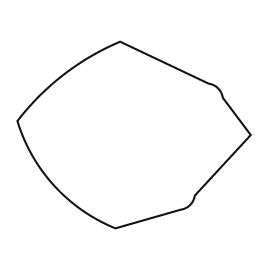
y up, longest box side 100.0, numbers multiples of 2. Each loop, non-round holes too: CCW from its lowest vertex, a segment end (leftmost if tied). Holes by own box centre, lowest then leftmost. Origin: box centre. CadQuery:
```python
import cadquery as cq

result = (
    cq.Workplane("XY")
    .moveTo(-8.0, -40.0)
    .lineTo(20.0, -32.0)
    .threePointArc((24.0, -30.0), (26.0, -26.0))
    .lineTo(50.0, 0.0)
    .lineTo(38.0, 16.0)
    .threePointArc((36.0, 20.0), (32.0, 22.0))
    .lineTo(-6.0, 40.0)
    .threePointArc((-30.0, 26.0), (-50.0, 6.0))
    .threePointArc((-34.0, -22.0), (-8.0, -40.0))
    .close()
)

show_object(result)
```